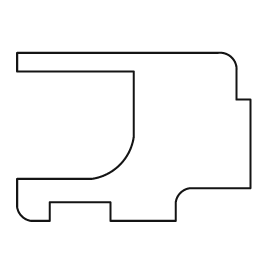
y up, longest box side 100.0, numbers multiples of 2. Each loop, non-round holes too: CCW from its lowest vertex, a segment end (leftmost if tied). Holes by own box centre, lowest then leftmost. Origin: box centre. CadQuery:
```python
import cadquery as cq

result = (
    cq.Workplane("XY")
    .moveTo(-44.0, -36.0)
    .lineTo(-36.0, -36.0)
    .lineTo(-36.0, -28.0)
    .lineTo(-10.0, -28.0)
    .lineTo(-10.0, -36.0)
    .lineTo(18.0, -36.0)
    .lineTo(18.0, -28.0)
    .threePointArc((20.0, -24.0), (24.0, -22.0))
    .lineTo(50.0, -22.0)
    .lineTo(50.0, 16.0)
    .lineTo(44.0, 16.0)
    .lineTo(44.0, 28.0)
    .threePointArc((42.0, 34.0), (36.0, 36.0))
    .lineTo(-50.0, 36.0)
    .lineTo(-50.0, 28.0)
    .lineTo(0.0, 28.0)
    .lineTo(0.0, 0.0)
    .threePointArc((-6.0, -12.0), (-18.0, -18.0))
    .lineTo(-50.0, -18.0)
    .lineTo(-50.0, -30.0)
    .threePointArc((-48.0, -34.0), (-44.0, -36.0))
    .close()
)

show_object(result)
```